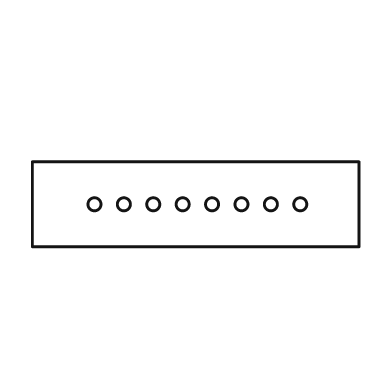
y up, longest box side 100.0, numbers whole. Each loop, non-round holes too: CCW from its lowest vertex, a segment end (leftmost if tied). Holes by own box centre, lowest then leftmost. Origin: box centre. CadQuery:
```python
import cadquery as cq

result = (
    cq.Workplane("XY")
    .moveTo(-50.0, -13.0)
    .lineTo(50.0, -13.0)
    .lineTo(50.0, 13.0)
    .lineTo(-50.0, 13.0)
    .close()
    .moveTo(-31.0, 0.0)
    .circle(2.0)
    .moveTo(-22.0, 0.0)
    .circle(2.0)
    .moveTo(-13.0, 0.0)
    .circle(2.0)
    .moveTo(-4.0, 0.0)
    .circle(2.0)
    .moveTo(5.0, 0.0)
    .circle(2.0)
    .moveTo(14.0, 0.0)
    .circle(2.0)
    .moveTo(23.0, 0.0)
    .circle(2.0)
    .moveTo(32.0, 0.0)
    .circle(2.0)
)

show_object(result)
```